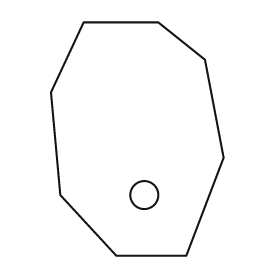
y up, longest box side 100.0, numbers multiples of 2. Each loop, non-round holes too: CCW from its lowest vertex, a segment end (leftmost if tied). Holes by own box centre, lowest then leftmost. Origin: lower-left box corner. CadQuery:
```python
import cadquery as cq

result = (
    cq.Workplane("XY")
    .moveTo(28.0, 0.0)
    .lineTo(58.0, 0.0)
    .lineTo(74.0, 42.0)
    .lineTo(66.0, 84.0)
    .lineTo(46.0, 100.0)
    .lineTo(14.0, 100.0)
    .lineTo(0.0, 70.0)
    .lineTo(4.0, 26.0)
    .close()
    .moveTo(40.0, 26.0)
    .circle(6.0)
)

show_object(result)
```